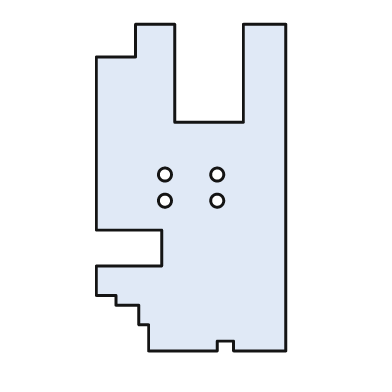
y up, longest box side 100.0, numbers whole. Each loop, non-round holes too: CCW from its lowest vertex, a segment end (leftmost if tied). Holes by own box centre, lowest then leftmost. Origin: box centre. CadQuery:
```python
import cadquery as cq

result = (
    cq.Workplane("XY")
    .moveTo(-13.0, -50.0)
    .lineTo(8.0, -50.0)
    .lineTo(8.0, -47.0)
    .lineTo(13.0, -47.0)
    .lineTo(13.0, -50.0)
    .lineTo(29.0, -50.0)
    .lineTo(29.0, 50.0)
    .lineTo(16.0, 50.0)
    .lineTo(16.0, 20.0)
    .lineTo(-5.0, 20.0)
    .lineTo(-5.0, 50.0)
    .lineTo(-17.0, 50.0)
    .lineTo(-17.0, 40.0)
    .lineTo(-29.0, 40.0)
    .lineTo(-29.0, -13.0)
    .lineTo(-9.0, -13.0)
    .lineTo(-9.0, -24.0)
    .lineTo(-29.0, -24.0)
    .lineTo(-29.0, -33.0)
    .lineTo(-23.0, -33.0)
    .lineTo(-23.0, -36.0)
    .lineTo(-16.0, -36.0)
    .lineTo(-16.0, -42.0)
    .lineTo(-13.0, -42.0)
    .close()
    .moveTo(-8.0, -4.0)
    .circle(2.0)
    .moveTo(8.0, -4.0)
    .circle(2.0)
    .moveTo(-8.0, 4.0)
    .circle(2.0)
    .moveTo(8.0, 4.0)
    .circle(2.0)
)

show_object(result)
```